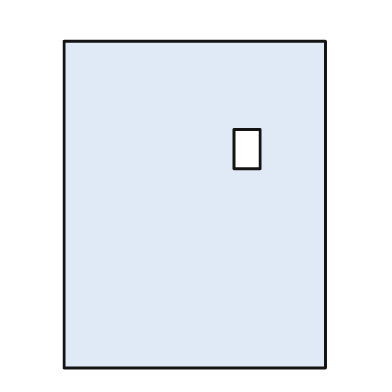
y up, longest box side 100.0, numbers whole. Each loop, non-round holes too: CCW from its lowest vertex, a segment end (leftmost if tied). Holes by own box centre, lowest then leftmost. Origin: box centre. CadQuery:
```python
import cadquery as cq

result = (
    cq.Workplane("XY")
    .moveTo(-40.0, -50.0)
    .lineTo(40.0, -50.0)
    .lineTo(40.0, 50.0)
    .lineTo(-40.0, 50.0)
    .close()
    .moveTo(12.0, 11.0)
    .lineTo(20.0, 11.0)
    .lineTo(20.0, 23.0)
    .lineTo(12.0, 23.0)
    .close()
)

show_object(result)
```